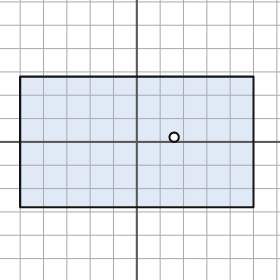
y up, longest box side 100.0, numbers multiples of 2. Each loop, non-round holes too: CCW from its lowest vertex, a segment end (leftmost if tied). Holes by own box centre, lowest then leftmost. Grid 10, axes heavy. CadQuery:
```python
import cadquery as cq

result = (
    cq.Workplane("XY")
    .moveTo(-50.0, -28.0)
    .lineTo(50.0, -28.0)
    .lineTo(50.0, 28.0)
    .lineTo(-50.0, 28.0)
    .close()
    .moveTo(16.0, 2.0)
    .circle(2.0)
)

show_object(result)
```